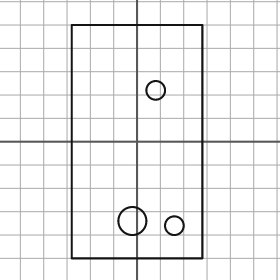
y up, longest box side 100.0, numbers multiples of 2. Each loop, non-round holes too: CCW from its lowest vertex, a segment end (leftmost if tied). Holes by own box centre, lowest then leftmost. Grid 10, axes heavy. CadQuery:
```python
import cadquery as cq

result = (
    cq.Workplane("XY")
    .moveTo(-28.0, -50.0)
    .lineTo(28.0, -50.0)
    .lineTo(28.0, 50.0)
    .lineTo(-28.0, 50.0)
    .close()
    .moveTo(16.0, -36.0)
    .circle(4.0)
    .moveTo(-2.0, -34.0)
    .circle(6.0)
    .moveTo(8.0, 22.0)
    .circle(4.0)
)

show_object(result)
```